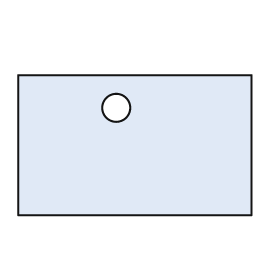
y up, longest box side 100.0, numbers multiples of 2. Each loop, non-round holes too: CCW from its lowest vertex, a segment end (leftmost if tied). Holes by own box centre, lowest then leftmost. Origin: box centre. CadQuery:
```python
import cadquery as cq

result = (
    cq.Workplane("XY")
    .moveTo(-50.0, -30.0)
    .lineTo(50.0, -30.0)
    .lineTo(50.0, 30.0)
    .lineTo(-50.0, 30.0)
    .close()
    .moveTo(-8.0, 16.0)
    .circle(6.0)
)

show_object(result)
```